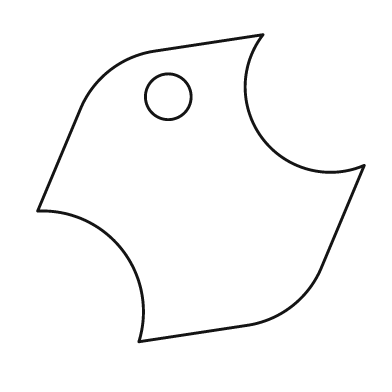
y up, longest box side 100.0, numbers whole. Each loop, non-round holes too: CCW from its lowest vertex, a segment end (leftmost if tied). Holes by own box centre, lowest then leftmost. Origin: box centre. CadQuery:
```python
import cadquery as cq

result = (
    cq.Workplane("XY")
    .moveTo(-19.0, -47.0)
    .lineTo(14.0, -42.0)
    .threePointArc((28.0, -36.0), (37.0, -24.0))
    .lineTo(50.0, 7.0)
    .threePointArc((19.0, 15.0), (19.0, 47.0))
    .lineTo(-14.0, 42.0)
    .threePointArc((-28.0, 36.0), (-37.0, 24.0))
    .lineTo(-50.0, -7.0)
    .threePointArc((-24.0, -19.0), (-19.0, -47.0))
    .close()
    .moveTo(-10.0, 28.0)
    .circle(7.0)
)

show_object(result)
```